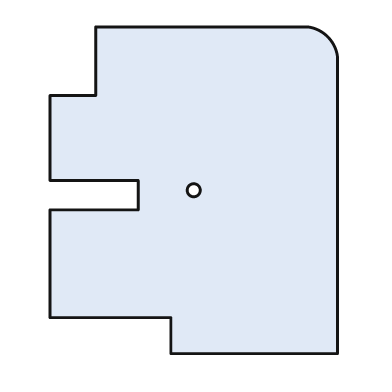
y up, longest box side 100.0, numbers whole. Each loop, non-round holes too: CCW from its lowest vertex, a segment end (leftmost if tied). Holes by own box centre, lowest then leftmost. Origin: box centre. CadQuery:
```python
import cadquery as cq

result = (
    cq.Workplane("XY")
    .moveTo(-7.0, -50.0)
    .lineTo(44.0, -50.0)
    .lineTo(44.0, 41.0)
    .threePointArc((41.0, 47.0), (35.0, 50.0))
    .lineTo(-30.0, 50.0)
    .lineTo(-30.0, 29.0)
    .lineTo(-44.0, 29.0)
    .lineTo(-44.0, 3.0)
    .lineTo(-17.0, 3.0)
    .lineTo(-17.0, -6.0)
    .lineTo(-44.0, -6.0)
    .lineTo(-44.0, -39.0)
    .lineTo(-7.0, -39.0)
    .close()
    .moveTo(0.0, 0.0)
    .circle(2.0)
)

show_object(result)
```